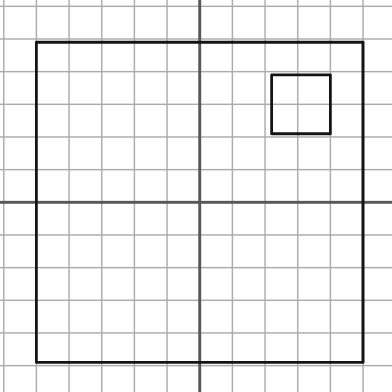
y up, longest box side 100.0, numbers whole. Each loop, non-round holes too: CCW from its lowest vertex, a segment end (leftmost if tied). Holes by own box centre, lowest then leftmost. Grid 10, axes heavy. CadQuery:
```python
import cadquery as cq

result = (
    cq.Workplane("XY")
    .moveTo(-50.0, -49.0)
    .lineTo(50.0, -49.0)
    .lineTo(50.0, 49.0)
    .lineTo(-50.0, 49.0)
    .close()
    .moveTo(22.0, 21.0)
    .lineTo(40.0, 21.0)
    .lineTo(40.0, 39.0)
    .lineTo(22.0, 39.0)
    .close()
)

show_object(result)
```